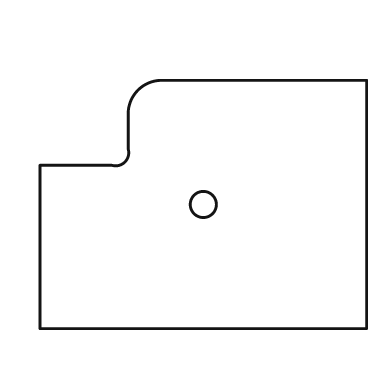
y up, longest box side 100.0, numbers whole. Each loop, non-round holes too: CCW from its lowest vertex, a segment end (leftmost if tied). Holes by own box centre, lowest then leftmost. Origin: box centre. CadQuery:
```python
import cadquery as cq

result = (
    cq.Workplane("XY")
    .moveTo(-50.0, -38.0)
    .lineTo(50.0, -38.0)
    .lineTo(50.0, 38.0)
    .lineTo(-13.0, 38.0)
    .threePointArc((-20.0, 35.0), (-23.0, 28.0))
    .lineTo(-23.0, 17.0)
    .threePointArc((-24.0, 13.0), (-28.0, 12.0))
    .lineTo(-50.0, 12.0)
    .close()
    .moveTo(0.0, 0.0)
    .circle(4.0)
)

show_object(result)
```